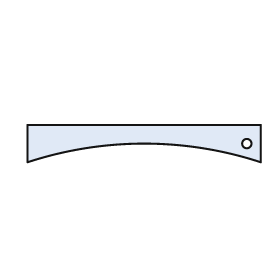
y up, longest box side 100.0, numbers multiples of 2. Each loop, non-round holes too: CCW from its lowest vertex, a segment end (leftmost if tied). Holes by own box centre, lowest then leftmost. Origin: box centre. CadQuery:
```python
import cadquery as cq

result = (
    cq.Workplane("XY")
    .moveTo(-50.0, -8.0)
    .threePointArc((0.0, 0.0), (50.0, -8.0))
    .lineTo(50.0, 8.0)
    .lineTo(-50.0, 8.0)
    .close()
    .moveTo(44.0, 0.0)
    .circle(2.0)
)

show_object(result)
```